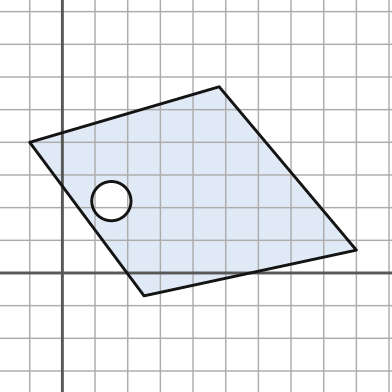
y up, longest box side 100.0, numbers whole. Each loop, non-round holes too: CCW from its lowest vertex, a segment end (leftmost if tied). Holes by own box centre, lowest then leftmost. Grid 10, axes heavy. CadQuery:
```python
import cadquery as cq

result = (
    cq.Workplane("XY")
    .moveTo(25.0, -7.0)
    .lineTo(90.0, 7.0)
    .lineTo(48.0, 57.0)
    .lineTo(-10.0, 40.0)
    .close()
    .moveTo(15.0, 22.0)
    .circle(6.0)
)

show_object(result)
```